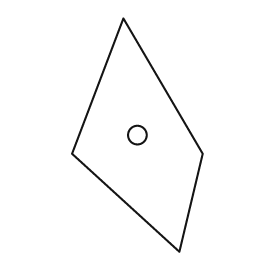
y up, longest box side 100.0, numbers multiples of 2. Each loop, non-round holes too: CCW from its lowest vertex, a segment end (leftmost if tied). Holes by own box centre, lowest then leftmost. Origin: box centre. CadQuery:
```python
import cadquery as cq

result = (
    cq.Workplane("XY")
    .moveTo(18.0, -50.0)
    .lineTo(28.0, -8.0)
    .lineTo(-6.0, 50.0)
    .lineTo(-28.0, -8.0)
    .close()
    .moveTo(0.0, 0.0)
    .circle(4.0)
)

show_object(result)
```